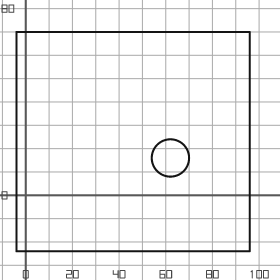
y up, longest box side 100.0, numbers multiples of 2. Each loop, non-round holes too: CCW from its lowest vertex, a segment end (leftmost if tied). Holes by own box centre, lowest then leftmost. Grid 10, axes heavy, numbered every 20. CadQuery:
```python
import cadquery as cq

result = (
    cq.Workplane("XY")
    .moveTo(-4.0, -24.0)
    .lineTo(96.0, -24.0)
    .lineTo(96.0, 70.0)
    .lineTo(-4.0, 70.0)
    .close()
    .moveTo(62.0, 16.0)
    .circle(8.0)
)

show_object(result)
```